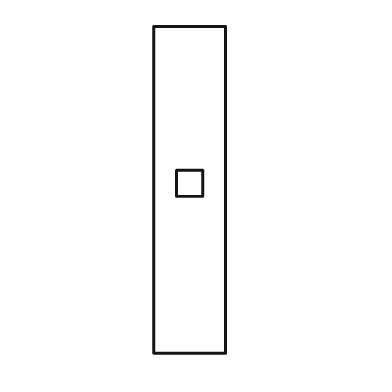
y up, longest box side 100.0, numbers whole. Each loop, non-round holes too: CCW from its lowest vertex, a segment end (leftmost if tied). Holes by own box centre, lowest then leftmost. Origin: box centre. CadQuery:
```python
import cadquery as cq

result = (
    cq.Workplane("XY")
    .moveTo(-11.0, -50.0)
    .lineTo(11.0, -50.0)
    .lineTo(11.0, 50.0)
    .lineTo(-11.0, 50.0)
    .close()
    .moveTo(-4.0, -2.0)
    .lineTo(4.0, -2.0)
    .lineTo(4.0, 6.0)
    .lineTo(-4.0, 6.0)
    .close()
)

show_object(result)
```